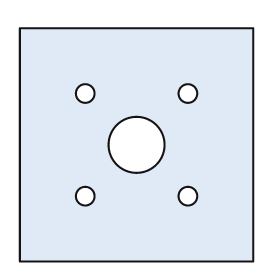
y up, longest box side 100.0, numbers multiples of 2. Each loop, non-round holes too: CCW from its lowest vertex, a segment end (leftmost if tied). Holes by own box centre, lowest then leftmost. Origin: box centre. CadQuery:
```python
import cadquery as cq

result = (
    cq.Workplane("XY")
    .moveTo(-50.0, -50.0)
    .lineTo(50.0, -50.0)
    .lineTo(50.0, 50.0)
    .lineTo(-50.0, 50.0)
    .close()
    .moveTo(-22.0, -22.0)
    .circle(4.0)
    .moveTo(22.0, -22.0)
    .circle(4.0)
    .moveTo(0.0, 0.0)
    .circle(12.0)
    .moveTo(-22.0, 22.0)
    .circle(4.0)
    .moveTo(22.0, 22.0)
    .circle(4.0)
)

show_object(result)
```